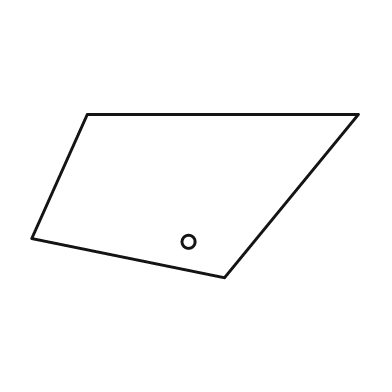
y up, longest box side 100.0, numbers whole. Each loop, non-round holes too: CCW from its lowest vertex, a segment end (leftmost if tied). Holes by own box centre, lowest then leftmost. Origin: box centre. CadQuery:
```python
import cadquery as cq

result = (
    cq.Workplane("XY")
    .moveTo(9.0, -25.0)
    .lineTo(50.0, 25.0)
    .lineTo(-33.0, 25.0)
    .lineTo(-50.0, -13.0)
    .close()
    .moveTo(-2.0, -14.0)
    .circle(2.0)
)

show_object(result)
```